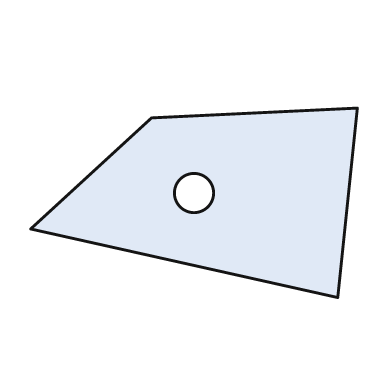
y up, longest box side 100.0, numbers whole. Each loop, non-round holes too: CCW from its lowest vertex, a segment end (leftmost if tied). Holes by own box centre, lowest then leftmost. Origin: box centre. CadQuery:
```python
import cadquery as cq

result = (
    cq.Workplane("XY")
    .moveTo(44.0, -29.0)
    .lineTo(50.0, 29.0)
    .lineTo(-13.0, 26.0)
    .lineTo(-50.0, -8.0)
    .close()
    .moveTo(0.0, 3.0)
    .circle(6.0)
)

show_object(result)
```